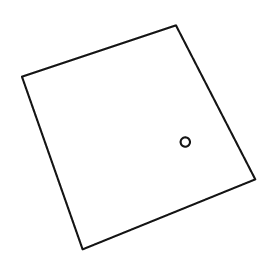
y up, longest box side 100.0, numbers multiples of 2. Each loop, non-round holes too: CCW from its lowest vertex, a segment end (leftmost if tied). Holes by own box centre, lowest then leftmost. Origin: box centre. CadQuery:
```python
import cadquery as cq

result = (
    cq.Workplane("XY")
    .moveTo(-24.0, -48.0)
    .lineTo(50.0, -18.0)
    .lineTo(16.0, 48.0)
    .lineTo(-50.0, 26.0)
    .close()
    .moveTo(20.0, -2.0)
    .circle(2.0)
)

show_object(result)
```